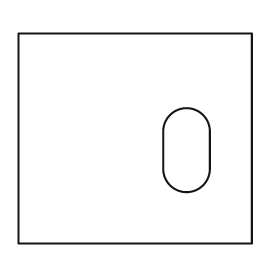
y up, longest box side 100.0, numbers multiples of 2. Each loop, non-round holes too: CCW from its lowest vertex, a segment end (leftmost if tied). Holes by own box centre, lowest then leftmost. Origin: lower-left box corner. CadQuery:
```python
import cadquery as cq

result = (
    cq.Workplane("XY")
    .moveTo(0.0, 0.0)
    .lineTo(100.0, 0.0)
    .lineTo(100.0, 90.0)
    .lineTo(0.0, 90.0)
    .close()
    .moveTo(62.0, 32.0)
    .threePointArc((72.0, 22.0), (82.0, 32.0))
    .lineTo(82.0, 48.0)
    .threePointArc((72.0, 58.0), (62.0, 48.0))
    .close()
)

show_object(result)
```